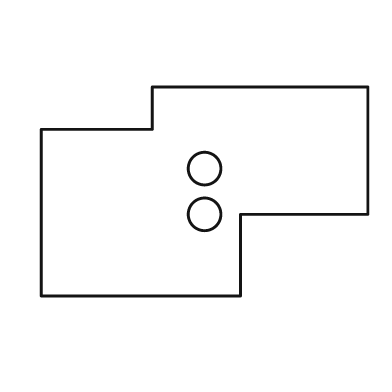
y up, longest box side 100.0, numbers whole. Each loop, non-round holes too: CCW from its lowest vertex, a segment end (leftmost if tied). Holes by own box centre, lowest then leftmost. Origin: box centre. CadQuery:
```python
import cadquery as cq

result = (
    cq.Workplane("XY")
    .moveTo(-50.0, -32.0)
    .lineTo(11.0, -32.0)
    .lineTo(11.0, -7.0)
    .lineTo(50.0, -7.0)
    .lineTo(50.0, 32.0)
    .lineTo(-16.0, 32.0)
    .lineTo(-16.0, 19.0)
    .lineTo(-50.0, 19.0)
    .close()
    .moveTo(0.0, -7.0)
    .circle(5.0)
    .moveTo(0.0, 7.0)
    .circle(5.0)
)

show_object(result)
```